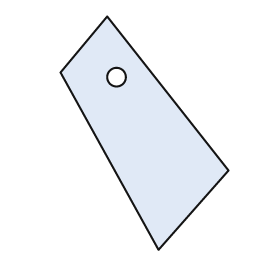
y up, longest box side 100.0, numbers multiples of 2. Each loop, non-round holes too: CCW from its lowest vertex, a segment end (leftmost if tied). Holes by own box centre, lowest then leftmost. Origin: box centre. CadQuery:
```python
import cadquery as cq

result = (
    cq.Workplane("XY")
    .moveTo(6.0, -50.0)
    .lineTo(36.0, -16.0)
    .lineTo(-16.0, 50.0)
    .lineTo(-36.0, 26.0)
    .close()
    .moveTo(-12.0, 24.0)
    .circle(4.0)
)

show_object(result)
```